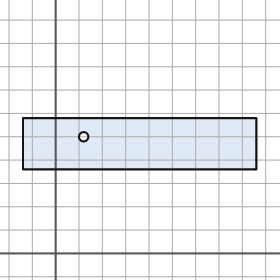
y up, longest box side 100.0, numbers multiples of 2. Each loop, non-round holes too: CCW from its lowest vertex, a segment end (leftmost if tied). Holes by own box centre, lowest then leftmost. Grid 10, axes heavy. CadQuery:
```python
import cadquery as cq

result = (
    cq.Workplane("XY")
    .moveTo(-14.0, 36.0)
    .lineTo(86.0, 36.0)
    .lineTo(86.0, 58.0)
    .lineTo(-14.0, 58.0)
    .close()
    .moveTo(12.0, 50.0)
    .circle(2.0)
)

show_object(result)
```